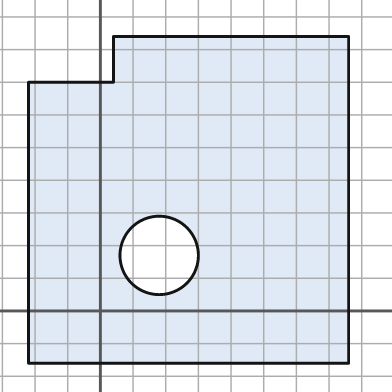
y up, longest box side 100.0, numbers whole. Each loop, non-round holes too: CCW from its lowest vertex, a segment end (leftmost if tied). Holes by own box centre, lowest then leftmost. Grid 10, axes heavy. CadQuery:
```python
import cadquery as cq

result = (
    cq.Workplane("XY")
    .moveTo(-22.0, -16.0)
    .lineTo(76.0, -16.0)
    .lineTo(76.0, 84.0)
    .lineTo(4.0, 84.0)
    .lineTo(4.0, 70.0)
    .lineTo(-22.0, 70.0)
    .close()
    .moveTo(18.0, 17.0)
    .circle(12.0)
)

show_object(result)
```